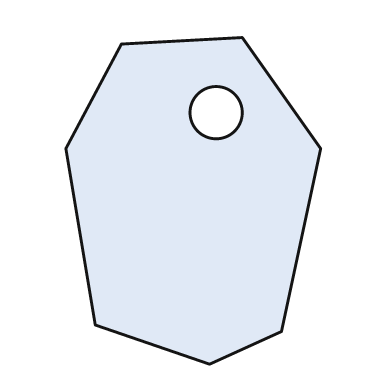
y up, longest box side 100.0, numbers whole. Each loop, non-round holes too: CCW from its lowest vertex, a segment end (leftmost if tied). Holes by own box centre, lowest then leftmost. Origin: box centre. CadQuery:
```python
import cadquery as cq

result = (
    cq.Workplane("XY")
    .moveTo(5.0, -50.0)
    .lineTo(27.0, -40.0)
    .lineTo(39.0, 16.0)
    .lineTo(15.0, 50.0)
    .lineTo(-22.0, 48.0)
    .lineTo(-39.0, 16.0)
    .lineTo(-30.0, -38.0)
    .close()
    .moveTo(7.0, 27.0)
    .circle(8.0)
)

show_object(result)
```